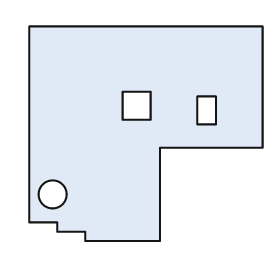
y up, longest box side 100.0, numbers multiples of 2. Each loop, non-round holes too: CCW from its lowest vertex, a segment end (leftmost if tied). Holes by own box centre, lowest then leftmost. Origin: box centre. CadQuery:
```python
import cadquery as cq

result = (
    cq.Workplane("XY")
    .moveTo(-26.0, -46.0)
    .lineTo(6.0, -46.0)
    .lineTo(6.0, -6.0)
    .lineTo(50.0, -6.0)
    .lineTo(50.0, 46.0)
    .lineTo(-50.0, 46.0)
    .lineTo(-50.0, -38.0)
    .lineTo(-38.0, -38.0)
    .lineTo(-38.0, -42.0)
    .lineTo(-26.0, -42.0)
    .close()
    .moveTo(-40.0, -26.0)
    .circle(6.0)
    .moveTo(22.0, 4.0)
    .lineTo(30.0, 4.0)
    .lineTo(30.0, 16.0)
    .lineTo(22.0, 16.0)
    .close()
    .moveTo(-10.0, 6.0)
    .lineTo(2.0, 6.0)
    .lineTo(2.0, 18.0)
    .lineTo(-10.0, 18.0)
    .close()
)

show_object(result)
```